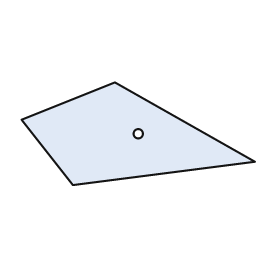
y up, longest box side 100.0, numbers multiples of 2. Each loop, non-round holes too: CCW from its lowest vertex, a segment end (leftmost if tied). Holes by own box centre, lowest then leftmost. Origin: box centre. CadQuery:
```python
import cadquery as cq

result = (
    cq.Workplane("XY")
    .moveTo(-28.0, -22.0)
    .lineTo(50.0, -12.0)
    .lineTo(-10.0, 22.0)
    .lineTo(-50.0, 6.0)
    .close()
    .moveTo(0.0, 0.0)
    .circle(2.0)
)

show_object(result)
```